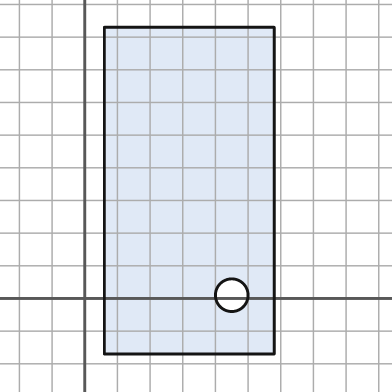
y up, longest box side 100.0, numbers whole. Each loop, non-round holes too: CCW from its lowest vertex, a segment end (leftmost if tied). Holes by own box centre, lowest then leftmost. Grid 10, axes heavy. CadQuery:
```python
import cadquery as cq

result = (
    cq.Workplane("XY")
    .moveTo(6.0, -17.0)
    .lineTo(58.0, -17.0)
    .lineTo(58.0, 83.0)
    .lineTo(6.0, 83.0)
    .close()
    .moveTo(45.0, 1.0)
    .circle(5.0)
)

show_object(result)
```